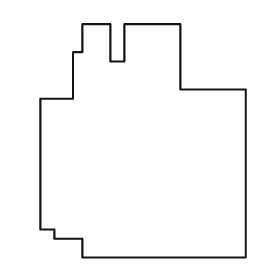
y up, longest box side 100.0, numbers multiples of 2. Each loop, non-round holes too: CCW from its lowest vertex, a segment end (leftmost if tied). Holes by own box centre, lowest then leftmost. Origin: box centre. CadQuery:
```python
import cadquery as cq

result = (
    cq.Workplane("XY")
    .moveTo(-26.0, -50.0)
    .lineTo(44.0, -50.0)
    .lineTo(44.0, 22.0)
    .lineTo(16.0, 22.0)
    .lineTo(16.0, 50.0)
    .lineTo(-8.0, 50.0)
    .lineTo(-8.0, 34.0)
    .lineTo(-14.0, 34.0)
    .lineTo(-14.0, 50.0)
    .lineTo(-26.0, 50.0)
    .lineTo(-26.0, 38.0)
    .lineTo(-30.0, 38.0)
    .lineTo(-30.0, 18.0)
    .lineTo(-44.0, 18.0)
    .lineTo(-44.0, -38.0)
    .lineTo(-38.0, -38.0)
    .lineTo(-38.0, -42.0)
    .lineTo(-26.0, -42.0)
    .close()
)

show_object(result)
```